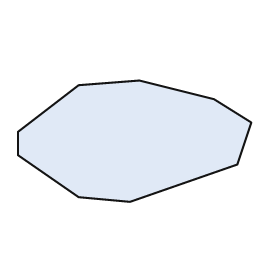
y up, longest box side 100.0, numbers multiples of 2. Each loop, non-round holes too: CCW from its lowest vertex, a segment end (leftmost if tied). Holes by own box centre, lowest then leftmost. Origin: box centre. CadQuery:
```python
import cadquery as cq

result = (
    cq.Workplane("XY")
    .moveTo(-2.0, -26.0)
    .lineTo(44.0, -10.0)
    .lineTo(50.0, 8.0)
    .lineTo(34.0, 18.0)
    .lineTo(2.0, 26.0)
    .lineTo(-24.0, 24.0)
    .lineTo(-50.0, 4.0)
    .lineTo(-50.0, -6.0)
    .lineTo(-24.0, -24.0)
    .close()
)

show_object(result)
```